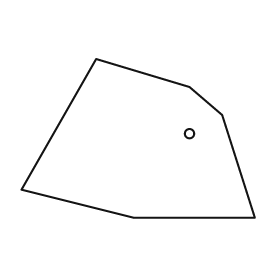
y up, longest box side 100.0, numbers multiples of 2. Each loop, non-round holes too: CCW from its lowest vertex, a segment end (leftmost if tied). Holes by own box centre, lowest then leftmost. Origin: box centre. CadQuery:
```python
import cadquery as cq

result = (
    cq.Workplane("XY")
    .moveTo(-2.0, -34.0)
    .lineTo(50.0, -34.0)
    .lineTo(36.0, 10.0)
    .lineTo(22.0, 22.0)
    .lineTo(-18.0, 34.0)
    .lineTo(-50.0, -22.0)
    .close()
    .moveTo(22.0, 2.0)
    .circle(2.0)
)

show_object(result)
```